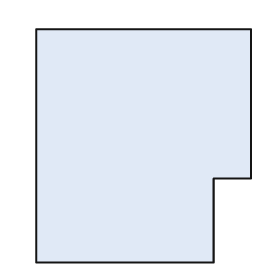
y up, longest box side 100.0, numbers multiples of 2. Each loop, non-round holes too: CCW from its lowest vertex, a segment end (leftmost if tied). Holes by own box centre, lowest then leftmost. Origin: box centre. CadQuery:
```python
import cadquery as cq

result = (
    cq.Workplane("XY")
    .moveTo(-46.0, -50.0)
    .lineTo(30.0, -50.0)
    .lineTo(30.0, -14.0)
    .lineTo(46.0, -14.0)
    .lineTo(46.0, 50.0)
    .lineTo(-46.0, 50.0)
    .close()
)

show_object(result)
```